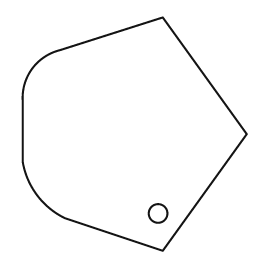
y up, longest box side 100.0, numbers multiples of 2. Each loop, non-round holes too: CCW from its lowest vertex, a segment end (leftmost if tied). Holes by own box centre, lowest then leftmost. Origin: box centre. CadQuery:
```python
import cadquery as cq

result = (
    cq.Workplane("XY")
    .moveTo(12.0, -50.0)
    .lineTo(48.0, 0.0)
    .lineTo(12.0, 50.0)
    .lineTo(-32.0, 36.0)
    .threePointArc((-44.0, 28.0), (-48.0, 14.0))
    .lineTo(-48.0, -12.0)
    .threePointArc((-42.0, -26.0), (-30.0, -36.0))
    .close()
    .moveTo(10.0, -34.0)
    .circle(4.0)
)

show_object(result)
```